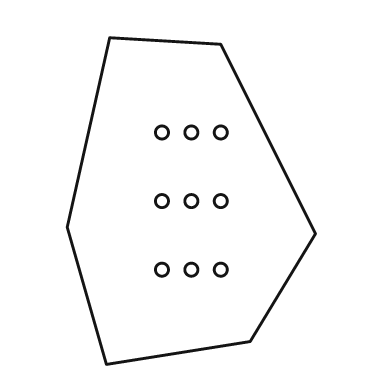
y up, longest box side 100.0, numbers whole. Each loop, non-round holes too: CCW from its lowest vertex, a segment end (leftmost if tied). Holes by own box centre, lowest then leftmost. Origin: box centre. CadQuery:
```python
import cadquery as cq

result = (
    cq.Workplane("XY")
    .moveTo(-26.0, -50.0)
    .lineTo(18.0, -43.0)
    .lineTo(38.0, -10.0)
    .lineTo(9.0, 48.0)
    .lineTo(-25.0, 50.0)
    .lineTo(-38.0, -8.0)
    .close()
    .moveTo(-9.0, -21.0)
    .circle(2.0)
    .moveTo(0.0, -21.0)
    .circle(2.0)
    .moveTo(9.0, -21.0)
    .circle(2.0)
    .moveTo(-9.0, 0.0)
    .circle(2.0)
    .moveTo(0.0, 0.0)
    .circle(2.0)
    .moveTo(9.0, 0.0)
    .circle(2.0)
    .moveTo(-9.0, 21.0)
    .circle(2.0)
    .moveTo(0.0, 21.0)
    .circle(2.0)
    .moveTo(9.0, 21.0)
    .circle(2.0)
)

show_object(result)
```